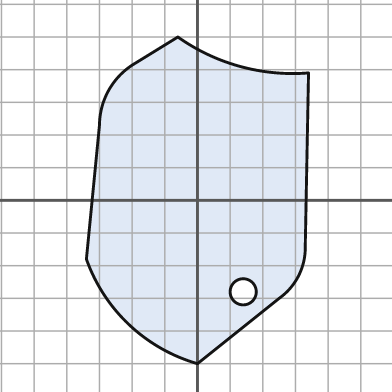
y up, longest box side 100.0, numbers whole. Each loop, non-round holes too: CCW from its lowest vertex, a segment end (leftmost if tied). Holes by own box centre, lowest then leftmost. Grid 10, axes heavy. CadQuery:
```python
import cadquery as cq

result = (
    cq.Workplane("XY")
    .moveTo(0.0, -50.0)
    .lineTo(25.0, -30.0)
    .threePointArc((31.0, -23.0), (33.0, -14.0))
    .lineTo(34.0, 39.0)
    .threePointArc((13.0, 41.0), (-6.0, 50.0))
    .lineTo(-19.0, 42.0)
    .threePointArc((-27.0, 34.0), (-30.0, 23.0))
    .lineTo(-34.0, -18.0)
    .threePointArc((-21.0, -38.0), (0.0, -50.0))
    .close()
    .moveTo(14.0, -28.0)
    .circle(4.0)
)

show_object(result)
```